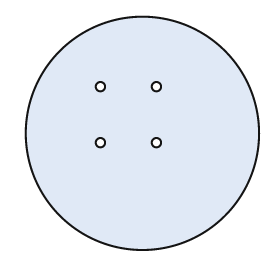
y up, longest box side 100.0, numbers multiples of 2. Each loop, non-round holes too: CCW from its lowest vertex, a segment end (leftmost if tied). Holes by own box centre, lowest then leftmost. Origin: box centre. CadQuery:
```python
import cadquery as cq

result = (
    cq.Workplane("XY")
    .moveTo(0.0, 0.0)
    .circle(50.0)
    .moveTo(-18.0, -4.0)
    .circle(2.0)
    .moveTo(6.0, -4.0)
    .circle(2.0)
    .moveTo(-18.0, 20.0)
    .circle(2.0)
    .moveTo(6.0, 20.0)
    .circle(2.0)
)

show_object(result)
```